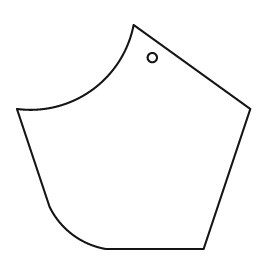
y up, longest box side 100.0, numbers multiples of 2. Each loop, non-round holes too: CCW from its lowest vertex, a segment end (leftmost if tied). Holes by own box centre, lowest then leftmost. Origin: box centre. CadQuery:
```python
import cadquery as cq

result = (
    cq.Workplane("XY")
    .moveTo(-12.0, -48.0)
    .lineTo(30.0, -48.0)
    .lineTo(50.0, 12.0)
    .lineTo(0.0, 48.0)
    .threePointArc((-18.0, 20.0), (-50.0, 12.0))
    .lineTo(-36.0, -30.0)
    .threePointArc((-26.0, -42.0), (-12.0, -48.0))
    .close()
    .moveTo(8.0, 34.0)
    .circle(2.0)
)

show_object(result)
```